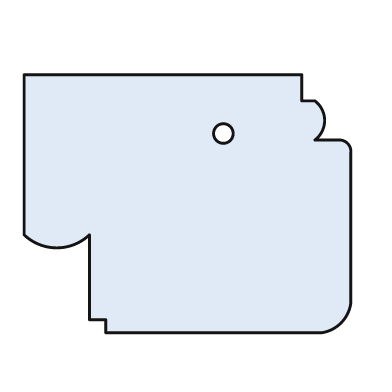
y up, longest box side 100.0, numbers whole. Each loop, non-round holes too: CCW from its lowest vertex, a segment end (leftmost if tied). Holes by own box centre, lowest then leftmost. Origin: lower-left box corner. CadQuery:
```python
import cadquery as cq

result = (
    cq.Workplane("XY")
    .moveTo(25.0, 0.0)
    .lineTo(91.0, 0.0)
    .threePointArc((97.0, 3.0), (100.0, 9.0))
    .lineTo(100.0, 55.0)
    .threePointArc((99.0, 58.0), (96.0, 59.0))
    .lineTo(89.0, 59.0)
    .threePointArc((92.0, 65.0), (89.0, 71.0))
    .lineTo(85.0, 71.0)
    .lineTo(85.0, 79.0)
    .lineTo(0.0, 79.0)
    .lineTo(0.0, 30.0)
    .threePointArc((10.0, 26.0), (20.0, 30.0))
    .lineTo(20.0, 4.0)
    .lineTo(25.0, 4.0)
    .close()
    .moveTo(61.0, 61.0)
    .circle(3.0)
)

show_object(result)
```